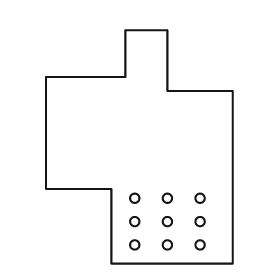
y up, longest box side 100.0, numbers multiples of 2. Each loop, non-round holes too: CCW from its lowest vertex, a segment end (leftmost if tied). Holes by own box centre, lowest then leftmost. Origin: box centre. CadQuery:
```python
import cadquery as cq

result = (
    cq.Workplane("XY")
    .moveTo(-12.0, -50.0)
    .lineTo(40.0, -50.0)
    .lineTo(40.0, 24.0)
    .lineTo(12.0, 24.0)
    .lineTo(12.0, 50.0)
    .lineTo(-6.0, 50.0)
    .lineTo(-6.0, 30.0)
    .lineTo(-40.0, 30.0)
    .lineTo(-40.0, -18.0)
    .lineTo(-12.0, -18.0)
    .close()
    .moveTo(-2.0, -42.0)
    .circle(2.0)
    .moveTo(12.0, -42.0)
    .circle(2.0)
    .moveTo(26.0, -42.0)
    .circle(2.0)
    .moveTo(-2.0, -32.0)
    .circle(2.0)
    .moveTo(12.0, -32.0)
    .circle(2.0)
    .moveTo(26.0, -32.0)
    .circle(2.0)
    .moveTo(-2.0, -22.0)
    .circle(2.0)
    .moveTo(12.0, -22.0)
    .circle(2.0)
    .moveTo(26.0, -22.0)
    .circle(2.0)
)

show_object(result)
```